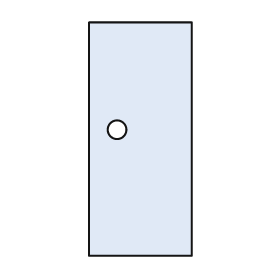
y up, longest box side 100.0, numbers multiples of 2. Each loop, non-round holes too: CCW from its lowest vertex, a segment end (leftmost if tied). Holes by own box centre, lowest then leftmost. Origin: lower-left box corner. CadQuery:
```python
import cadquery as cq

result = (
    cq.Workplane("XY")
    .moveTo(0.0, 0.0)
    .lineTo(44.0, 0.0)
    .lineTo(44.0, 100.0)
    .lineTo(0.0, 100.0)
    .close()
    .moveTo(12.0, 54.0)
    .circle(4.0)
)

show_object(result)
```